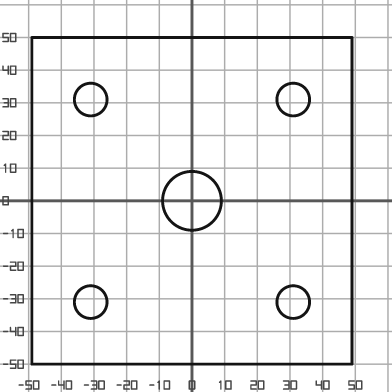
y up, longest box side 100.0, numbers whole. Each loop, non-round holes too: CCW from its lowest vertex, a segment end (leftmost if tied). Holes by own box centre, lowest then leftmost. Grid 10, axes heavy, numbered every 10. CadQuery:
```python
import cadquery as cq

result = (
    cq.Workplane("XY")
    .moveTo(-49.0, -50.0)
    .lineTo(49.0, -50.0)
    .lineTo(49.0, 50.0)
    .lineTo(-49.0, 50.0)
    .close()
    .moveTo(-31.0, -31.0)
    .circle(5.0)
    .moveTo(31.0, -31.0)
    .circle(5.0)
    .moveTo(0.0, 0.0)
    .circle(9.0)
    .moveTo(-31.0, 31.0)
    .circle(5.0)
    .moveTo(31.0, 31.0)
    .circle(5.0)
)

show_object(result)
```